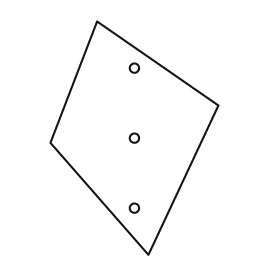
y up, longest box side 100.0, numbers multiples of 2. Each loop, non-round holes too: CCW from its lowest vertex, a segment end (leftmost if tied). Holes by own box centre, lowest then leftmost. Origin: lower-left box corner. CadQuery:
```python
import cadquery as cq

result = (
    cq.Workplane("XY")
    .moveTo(42.0, 0.0)
    .lineTo(72.0, 64.0)
    .lineTo(20.0, 100.0)
    .lineTo(0.0, 48.0)
    .close()
    .moveTo(36.0, 20.0)
    .circle(2.0)
    .moveTo(36.0, 50.0)
    .circle(2.0)
    .moveTo(36.0, 80.0)
    .circle(2.0)
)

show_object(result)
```